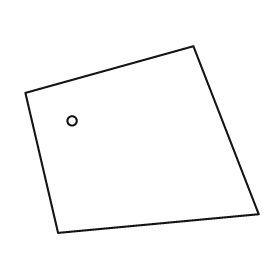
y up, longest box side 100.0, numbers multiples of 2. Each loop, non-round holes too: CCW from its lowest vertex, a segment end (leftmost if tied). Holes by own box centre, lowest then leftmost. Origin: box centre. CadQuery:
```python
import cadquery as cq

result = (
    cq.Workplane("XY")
    .moveTo(-36.0, -40.0)
    .lineTo(50.0, -32.0)
    .lineTo(22.0, 40.0)
    .lineTo(-50.0, 20.0)
    .close()
    .moveTo(-30.0, 8.0)
    .circle(2.0)
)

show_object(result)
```